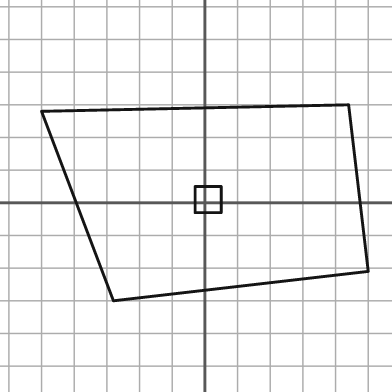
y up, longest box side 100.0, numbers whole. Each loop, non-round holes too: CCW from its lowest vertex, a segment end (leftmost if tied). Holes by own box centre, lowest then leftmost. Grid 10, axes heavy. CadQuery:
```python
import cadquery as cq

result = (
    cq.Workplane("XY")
    .moveTo(-28.0, -30.0)
    .lineTo(50.0, -21.0)
    .lineTo(44.0, 30.0)
    .lineTo(-50.0, 28.0)
    .close()
    .moveTo(-3.0, -3.0)
    .lineTo(5.0, -3.0)
    .lineTo(5.0, 5.0)
    .lineTo(-3.0, 5.0)
    .close()
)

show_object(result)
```